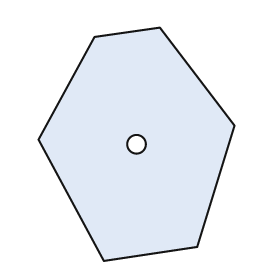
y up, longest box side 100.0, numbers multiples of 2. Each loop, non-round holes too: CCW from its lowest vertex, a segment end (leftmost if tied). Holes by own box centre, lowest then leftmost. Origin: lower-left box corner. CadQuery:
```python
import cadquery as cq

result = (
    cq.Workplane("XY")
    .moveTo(28.0, 0.0)
    .lineTo(68.0, 6.0)
    .lineTo(84.0, 58.0)
    .lineTo(52.0, 100.0)
    .lineTo(24.0, 96.0)
    .lineTo(0.0, 52.0)
    .close()
    .moveTo(42.0, 50.0)
    .circle(4.0)
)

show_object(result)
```